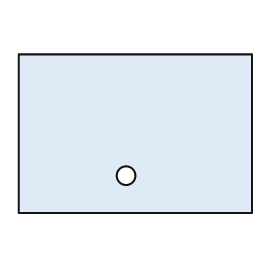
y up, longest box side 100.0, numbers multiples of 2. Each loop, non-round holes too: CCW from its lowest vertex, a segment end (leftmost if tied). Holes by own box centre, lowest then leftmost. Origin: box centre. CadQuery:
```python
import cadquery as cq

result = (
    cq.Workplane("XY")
    .moveTo(-50.0, -34.0)
    .lineTo(50.0, -34.0)
    .lineTo(50.0, 34.0)
    .lineTo(-50.0, 34.0)
    .close()
    .moveTo(-4.0, -18.0)
    .circle(4.0)
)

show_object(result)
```